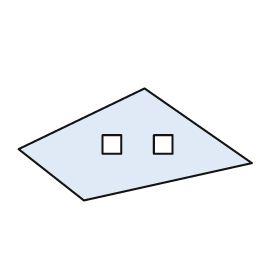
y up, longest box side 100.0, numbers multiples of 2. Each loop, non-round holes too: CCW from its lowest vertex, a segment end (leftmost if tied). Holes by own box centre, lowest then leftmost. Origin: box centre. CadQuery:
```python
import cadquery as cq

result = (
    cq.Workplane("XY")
    .moveTo(-22.0, -24.0)
    .lineTo(50.0, -8.0)
    .lineTo(4.0, 24.0)
    .lineTo(-50.0, -2.0)
    .close()
    .moveTo(-14.0, -4.0)
    .lineTo(-6.0, -4.0)
    .lineTo(-6.0, 4.0)
    .lineTo(-14.0, 4.0)
    .close()
    .moveTo(8.0, -4.0)
    .lineTo(16.0, -4.0)
    .lineTo(16.0, 4.0)
    .lineTo(8.0, 4.0)
    .close()
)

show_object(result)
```